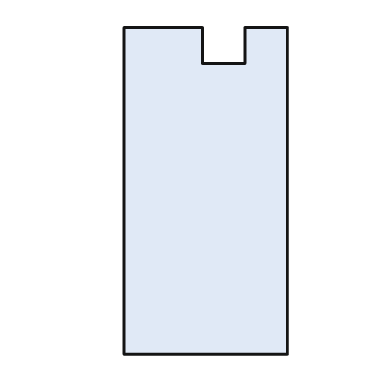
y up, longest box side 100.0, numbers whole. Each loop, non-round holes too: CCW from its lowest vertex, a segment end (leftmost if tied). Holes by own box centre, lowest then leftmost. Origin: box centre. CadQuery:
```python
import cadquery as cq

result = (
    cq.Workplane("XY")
    .moveTo(-25.0, -50.0)
    .lineTo(25.0, -50.0)
    .lineTo(25.0, 50.0)
    .lineTo(12.0, 50.0)
    .lineTo(12.0, 39.0)
    .lineTo(-1.0, 39.0)
    .lineTo(-1.0, 50.0)
    .lineTo(-25.0, 50.0)
    .close()
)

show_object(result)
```